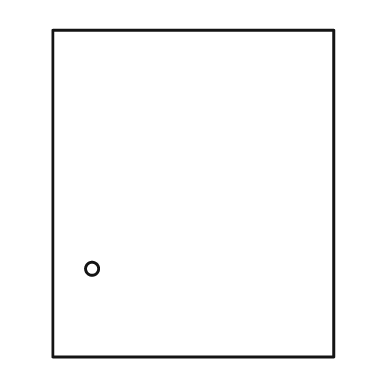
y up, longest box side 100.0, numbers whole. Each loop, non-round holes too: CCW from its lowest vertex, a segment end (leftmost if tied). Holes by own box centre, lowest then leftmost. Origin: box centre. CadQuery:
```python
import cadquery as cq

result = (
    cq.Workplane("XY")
    .moveTo(-43.0, -50.0)
    .lineTo(43.0, -50.0)
    .lineTo(43.0, 50.0)
    .lineTo(-43.0, 50.0)
    .close()
    .moveTo(-31.0, -23.0)
    .circle(2.0)
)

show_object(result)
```